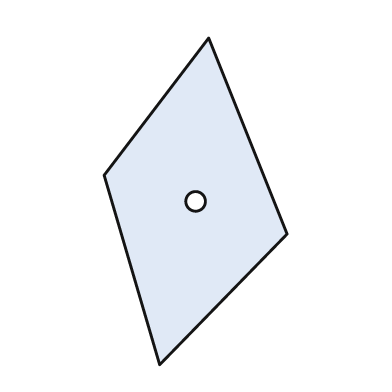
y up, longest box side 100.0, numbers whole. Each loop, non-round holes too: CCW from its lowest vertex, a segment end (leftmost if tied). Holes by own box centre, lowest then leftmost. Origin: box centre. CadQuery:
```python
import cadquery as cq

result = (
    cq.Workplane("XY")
    .moveTo(-11.0, -50.0)
    .lineTo(28.0, -10.0)
    .lineTo(4.0, 50.0)
    .lineTo(-28.0, 8.0)
    .close()
    .moveTo(0.0, 0.0)
    .circle(3.0)
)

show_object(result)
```